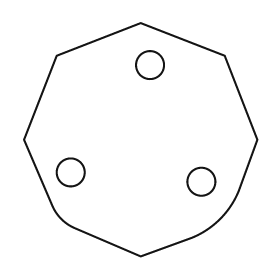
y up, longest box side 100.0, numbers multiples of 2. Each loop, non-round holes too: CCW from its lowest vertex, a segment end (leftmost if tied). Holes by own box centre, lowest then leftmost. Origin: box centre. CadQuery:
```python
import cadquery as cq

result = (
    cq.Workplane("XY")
    .moveTo(0.0, -50.0)
    .lineTo(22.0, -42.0)
    .threePointArc((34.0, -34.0), (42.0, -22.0))
    .lineTo(50.0, 0.0)
    .lineTo(36.0, 36.0)
    .lineTo(0.0, 50.0)
    .lineTo(-36.0, 36.0)
    .lineTo(-50.0, 0.0)
    .lineTo(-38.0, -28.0)
    .threePointArc((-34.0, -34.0), (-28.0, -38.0))
    .close()
    .moveTo(26.0, -18.0)
    .circle(6.0)
    .moveTo(-30.0, -14.0)
    .circle(6.0)
    .moveTo(4.0, 32.0)
    .circle(6.0)
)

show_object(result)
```